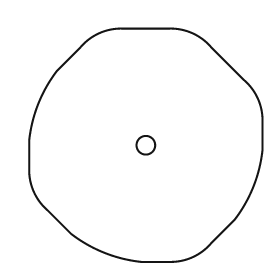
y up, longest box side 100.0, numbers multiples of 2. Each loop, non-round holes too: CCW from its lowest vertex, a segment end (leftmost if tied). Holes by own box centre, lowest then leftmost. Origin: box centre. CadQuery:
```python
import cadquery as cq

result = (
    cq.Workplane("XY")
    .moveTo(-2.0, -50.0)
    .lineTo(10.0, -50.0)
    .threePointArc((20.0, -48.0), (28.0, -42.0))
    .lineTo(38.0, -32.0)
    .threePointArc((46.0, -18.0), (50.0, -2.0))
    .lineTo(50.0, 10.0)
    .threePointArc((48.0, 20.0), (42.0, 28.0))
    .lineTo(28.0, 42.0)
    .threePointArc((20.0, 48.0), (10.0, 50.0))
    .lineTo(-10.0, 50.0)
    .threePointArc((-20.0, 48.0), (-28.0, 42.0))
    .lineTo(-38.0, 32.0)
    .threePointArc((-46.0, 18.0), (-50.0, 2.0))
    .lineTo(-50.0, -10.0)
    .threePointArc((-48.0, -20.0), (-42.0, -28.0))
    .lineTo(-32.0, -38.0)
    .threePointArc((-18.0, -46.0), (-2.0, -50.0))
    .close()
    .moveTo(0.0, 0.0)
    .circle(4.0)
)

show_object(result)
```